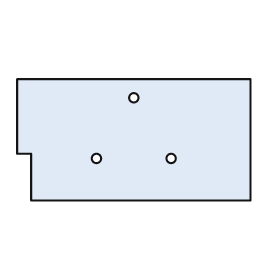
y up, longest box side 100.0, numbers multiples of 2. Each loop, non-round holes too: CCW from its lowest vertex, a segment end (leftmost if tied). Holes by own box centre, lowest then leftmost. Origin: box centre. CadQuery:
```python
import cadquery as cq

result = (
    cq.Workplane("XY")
    .moveTo(-44.0, -26.0)
    .lineTo(50.0, -26.0)
    .lineTo(50.0, 26.0)
    .lineTo(-50.0, 26.0)
    .lineTo(-50.0, -6.0)
    .lineTo(-44.0, -6.0)
    .close()
    .moveTo(-16.0, -8.0)
    .circle(2.0)
    .moveTo(16.0, -8.0)
    .circle(2.0)
    .moveTo(0.0, 18.0)
    .circle(2.0)
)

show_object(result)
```